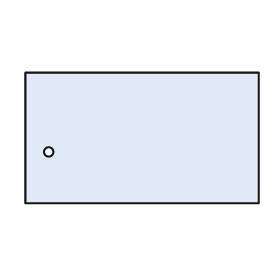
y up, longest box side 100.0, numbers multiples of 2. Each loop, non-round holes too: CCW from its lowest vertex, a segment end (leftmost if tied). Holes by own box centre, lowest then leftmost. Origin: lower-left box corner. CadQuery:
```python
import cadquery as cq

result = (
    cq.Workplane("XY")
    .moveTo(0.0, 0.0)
    .lineTo(100.0, 0.0)
    .lineTo(100.0, 56.0)
    .lineTo(0.0, 56.0)
    .close()
    .moveTo(10.0, 22.0)
    .circle(2.0)
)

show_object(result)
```